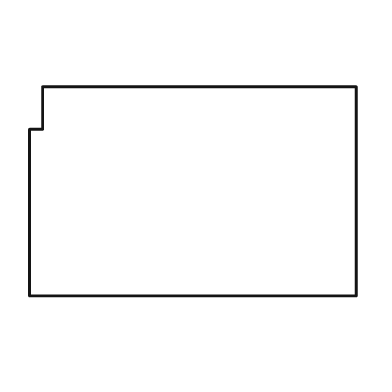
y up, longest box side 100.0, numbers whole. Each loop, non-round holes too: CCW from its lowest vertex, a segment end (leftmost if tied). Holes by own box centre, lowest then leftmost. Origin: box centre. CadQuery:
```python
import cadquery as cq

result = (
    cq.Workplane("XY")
    .moveTo(-50.0, -32.0)
    .lineTo(50.0, -32.0)
    .lineTo(50.0, 32.0)
    .lineTo(-46.0, 32.0)
    .lineTo(-46.0, 19.0)
    .lineTo(-50.0, 19.0)
    .close()
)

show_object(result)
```